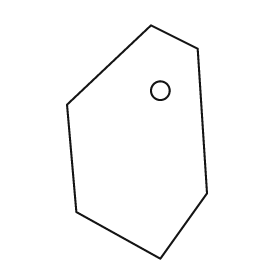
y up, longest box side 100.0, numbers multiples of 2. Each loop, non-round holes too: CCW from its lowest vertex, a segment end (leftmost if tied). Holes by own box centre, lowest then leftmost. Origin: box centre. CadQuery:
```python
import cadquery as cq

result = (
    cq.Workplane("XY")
    .moveTo(10.0, -50.0)
    .lineTo(30.0, -22.0)
    .lineTo(26.0, 40.0)
    .lineTo(6.0, 50.0)
    .lineTo(-30.0, 16.0)
    .lineTo(-26.0, -30.0)
    .close()
    .moveTo(10.0, 22.0)
    .circle(4.0)
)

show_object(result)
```